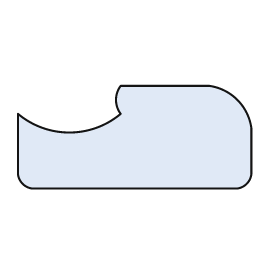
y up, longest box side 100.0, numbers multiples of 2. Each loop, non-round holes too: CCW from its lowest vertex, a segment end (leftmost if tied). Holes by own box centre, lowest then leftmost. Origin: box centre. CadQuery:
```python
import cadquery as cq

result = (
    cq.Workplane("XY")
    .moveTo(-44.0, -22.0)
    .lineTo(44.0, -22.0)
    .threePointArc((48.0, -20.0), (50.0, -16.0))
    .lineTo(50.0, 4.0)
    .threePointArc((44.0, 16.0), (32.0, 22.0))
    .lineTo(-6.0, 22.0)
    .threePointArc((-8.0, 16.0), (-6.0, 10.0))
    .threePointArc((-28.0, 2.0), (-50.0, 10.0))
    .lineTo(-50.0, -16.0)
    .threePointArc((-48.0, -20.0), (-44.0, -22.0))
    .close()
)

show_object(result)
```